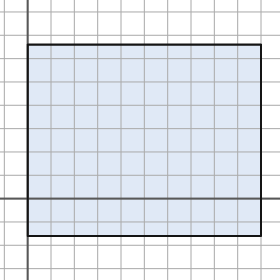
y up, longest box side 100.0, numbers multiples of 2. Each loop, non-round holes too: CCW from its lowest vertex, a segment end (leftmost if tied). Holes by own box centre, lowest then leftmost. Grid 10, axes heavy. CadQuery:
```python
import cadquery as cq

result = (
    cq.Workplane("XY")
    .moveTo(0.0, -16.0)
    .lineTo(100.0, -16.0)
    .lineTo(100.0, 66.0)
    .lineTo(0.0, 66.0)
    .close()
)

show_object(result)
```